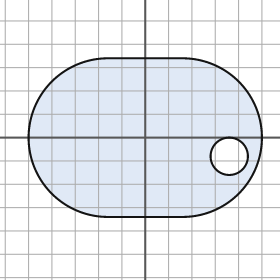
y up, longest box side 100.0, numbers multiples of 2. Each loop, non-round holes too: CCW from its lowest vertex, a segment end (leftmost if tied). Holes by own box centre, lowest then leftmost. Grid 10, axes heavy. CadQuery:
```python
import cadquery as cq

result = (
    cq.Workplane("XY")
    .moveTo(-16.0, -34.0)
    .lineTo(16.0, -34.0)
    .threePointArc((50.0, 0.0), (16.0, 34.0))
    .lineTo(-16.0, 34.0)
    .threePointArc((-50.0, 0.0), (-16.0, -34.0))
    .close()
    .moveTo(36.0, -8.0)
    .circle(8.0)
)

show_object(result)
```